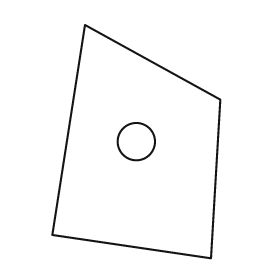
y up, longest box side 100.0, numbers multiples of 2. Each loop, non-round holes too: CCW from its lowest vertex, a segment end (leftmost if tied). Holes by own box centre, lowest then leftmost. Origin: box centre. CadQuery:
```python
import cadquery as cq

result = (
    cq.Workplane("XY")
    .moveTo(32.0, -50.0)
    .lineTo(36.0, 18.0)
    .lineTo(-22.0, 50.0)
    .lineTo(-36.0, -40.0)
    .close()
    .moveTo(0.0, 0.0)
    .circle(8.0)
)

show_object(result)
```